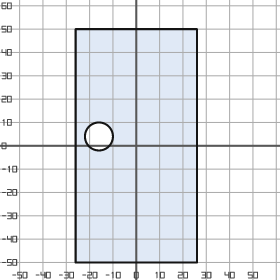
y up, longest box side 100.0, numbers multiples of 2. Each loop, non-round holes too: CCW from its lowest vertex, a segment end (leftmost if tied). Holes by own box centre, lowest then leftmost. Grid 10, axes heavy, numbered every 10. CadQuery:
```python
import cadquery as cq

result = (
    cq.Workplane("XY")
    .moveTo(-26.0, -50.0)
    .lineTo(26.0, -50.0)
    .lineTo(26.0, 50.0)
    .lineTo(-26.0, 50.0)
    .close()
    .moveTo(-16.0, 4.0)
    .circle(6.0)
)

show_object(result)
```